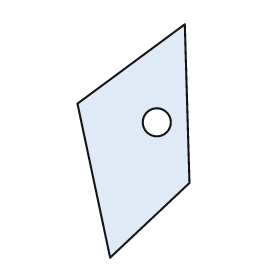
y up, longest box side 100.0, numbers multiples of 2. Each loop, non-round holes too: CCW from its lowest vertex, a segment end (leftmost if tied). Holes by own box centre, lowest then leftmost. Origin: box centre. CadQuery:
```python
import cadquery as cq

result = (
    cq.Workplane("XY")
    .moveTo(-10.0, -50.0)
    .lineTo(24.0, -18.0)
    .lineTo(22.0, 50.0)
    .lineTo(-24.0, 16.0)
    .close()
    .moveTo(10.0, 8.0)
    .circle(6.0)
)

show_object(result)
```